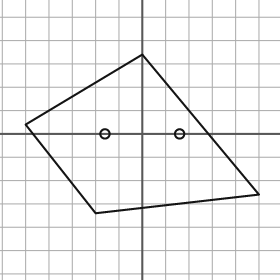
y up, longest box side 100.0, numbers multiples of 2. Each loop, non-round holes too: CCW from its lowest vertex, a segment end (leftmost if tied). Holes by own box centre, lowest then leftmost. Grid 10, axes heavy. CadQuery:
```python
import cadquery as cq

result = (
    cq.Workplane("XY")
    .moveTo(-20.0, -34.0)
    .lineTo(50.0, -26.0)
    .lineTo(0.0, 34.0)
    .lineTo(-50.0, 4.0)
    .close()
    .moveTo(-16.0, 0.0)
    .circle(2.0)
    .moveTo(16.0, 0.0)
    .circle(2.0)
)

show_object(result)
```